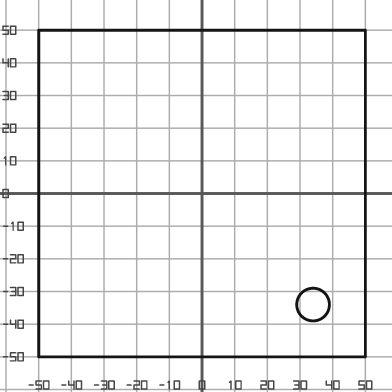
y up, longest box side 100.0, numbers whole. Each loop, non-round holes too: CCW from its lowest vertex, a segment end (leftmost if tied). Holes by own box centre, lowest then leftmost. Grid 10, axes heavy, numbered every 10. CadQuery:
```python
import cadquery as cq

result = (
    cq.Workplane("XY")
    .moveTo(-50.0, -50.0)
    .lineTo(50.0, -50.0)
    .lineTo(50.0, 50.0)
    .lineTo(-50.0, 50.0)
    .close()
    .moveTo(34.0, -34.0)
    .circle(5.0)
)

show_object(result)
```